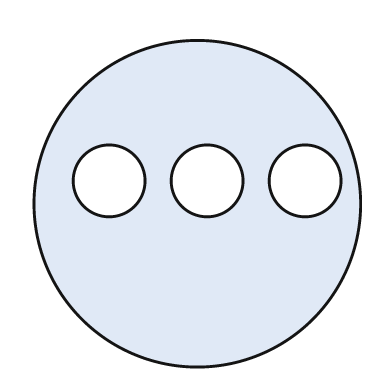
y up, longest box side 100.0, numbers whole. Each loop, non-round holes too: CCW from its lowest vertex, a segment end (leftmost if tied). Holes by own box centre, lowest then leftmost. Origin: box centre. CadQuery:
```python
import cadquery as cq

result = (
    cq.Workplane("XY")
    .moveTo(0.0, 0.0)
    .circle(50.0)
    .moveTo(-27.0, 7.0)
    .circle(11.0)
    .moveTo(3.0, 7.0)
    .circle(11.0)
    .moveTo(33.0, 7.0)
    .circle(11.0)
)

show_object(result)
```